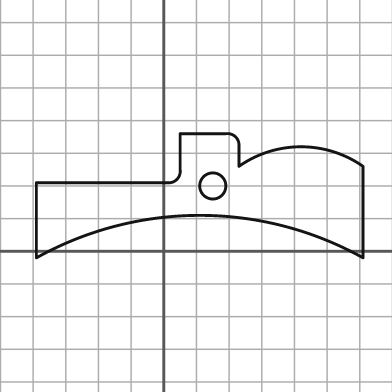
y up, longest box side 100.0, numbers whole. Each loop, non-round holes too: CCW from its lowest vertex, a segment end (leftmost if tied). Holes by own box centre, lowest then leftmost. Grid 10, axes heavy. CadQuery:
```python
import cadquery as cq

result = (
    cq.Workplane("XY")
    .moveTo(-39.0, -2.0)
    .threePointArc((11.0, 11.0), (61.0, -2.0))
    .lineTo(61.0, 26.0)
    .threePointArc((42.0, 32.0), (23.0, 26.0))
    .lineTo(23.0, 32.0)
    .threePointArc((22.0, 35.0), (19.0, 36.0))
    .lineTo(5.0, 36.0)
    .lineTo(5.0, 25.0)
    .threePointArc((4.0, 22.0), (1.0, 21.0))
    .lineTo(-39.0, 21.0)
    .close()
    .moveTo(15.0, 20.0)
    .circle(4.0)
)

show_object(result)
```